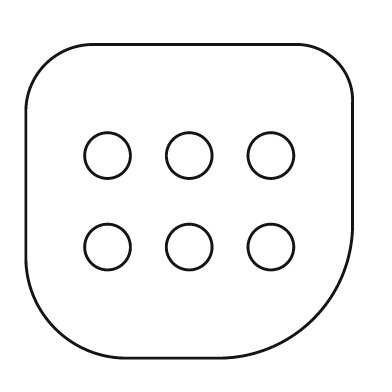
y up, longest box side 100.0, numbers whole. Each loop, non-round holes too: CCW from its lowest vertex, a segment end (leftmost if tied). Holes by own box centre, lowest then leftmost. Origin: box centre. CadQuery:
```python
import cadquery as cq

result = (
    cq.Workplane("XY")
    .moveTo(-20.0, -48.0)
    .lineTo(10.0, -48.0)
    .threePointArc((38.0, -36.0), (50.0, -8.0))
    .lineTo(50.0, 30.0)
    .threePointArc((45.0, 43.0), (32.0, 48.0))
    .lineTo(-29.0, 48.0)
    .threePointArc((-44.0, 42.0), (-50.0, 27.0))
    .lineTo(-50.0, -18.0)
    .threePointArc((-41.0, -39.0), (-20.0, -48.0))
    .close()
    .moveTo(-25.0, -14.0)
    .circle(7.0)
    .moveTo(0.0, -14.0)
    .circle(7.0)
    .moveTo(25.0, -14.0)
    .circle(7.0)
    .moveTo(-25.0, 14.0)
    .circle(7.0)
    .moveTo(0.0, 14.0)
    .circle(7.0)
    .moveTo(25.0, 14.0)
    .circle(7.0)
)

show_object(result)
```